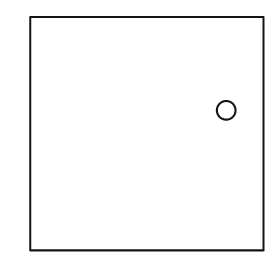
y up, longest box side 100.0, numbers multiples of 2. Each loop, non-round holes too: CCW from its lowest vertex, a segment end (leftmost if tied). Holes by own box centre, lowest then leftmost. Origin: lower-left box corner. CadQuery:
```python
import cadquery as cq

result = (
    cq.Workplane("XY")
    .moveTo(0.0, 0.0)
    .lineTo(100.0, 0.0)
    .lineTo(100.0, 100.0)
    .lineTo(0.0, 100.0)
    .close()
    .moveTo(84.0, 60.0)
    .circle(4.0)
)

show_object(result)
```